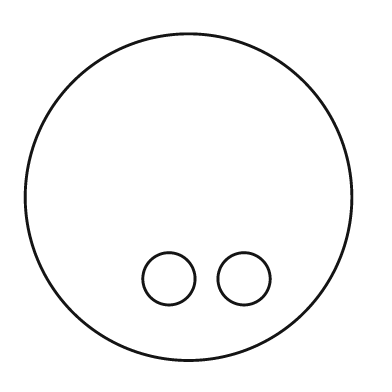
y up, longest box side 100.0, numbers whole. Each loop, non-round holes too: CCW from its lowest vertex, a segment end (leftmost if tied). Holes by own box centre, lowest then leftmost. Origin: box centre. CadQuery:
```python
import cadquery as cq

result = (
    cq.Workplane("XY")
    .moveTo(0.0, 0.0)
    .circle(50.0)
    .moveTo(-6.0, -25.0)
    .circle(8.0)
    .moveTo(17.0, -25.0)
    .circle(8.0)
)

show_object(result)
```